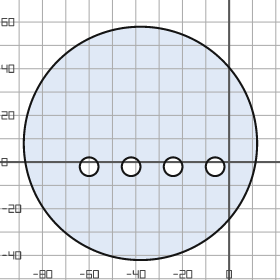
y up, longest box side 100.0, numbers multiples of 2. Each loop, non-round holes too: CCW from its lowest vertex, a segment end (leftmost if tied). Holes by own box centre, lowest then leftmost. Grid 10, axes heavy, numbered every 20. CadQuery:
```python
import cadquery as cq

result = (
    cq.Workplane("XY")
    .moveTo(-38.0, 8.0)
    .circle(50.0)
    .moveTo(-60.0, -2.0)
    .circle(4.0)
    .moveTo(-42.0, -2.0)
    .circle(4.0)
    .moveTo(-24.0, -2.0)
    .circle(4.0)
    .moveTo(-6.0, -2.0)
    .circle(4.0)
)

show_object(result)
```